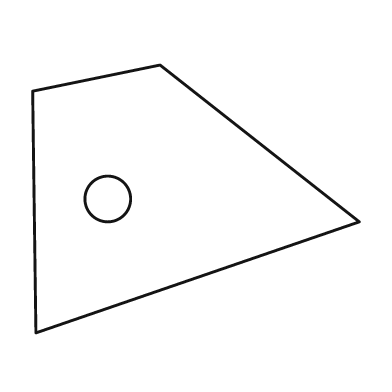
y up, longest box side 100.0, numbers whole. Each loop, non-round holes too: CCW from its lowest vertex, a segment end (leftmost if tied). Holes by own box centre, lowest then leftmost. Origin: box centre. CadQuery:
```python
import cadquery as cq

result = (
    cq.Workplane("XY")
    .moveTo(-49.0, -41.0)
    .lineTo(50.0, -7.0)
    .lineTo(-11.0, 41.0)
    .lineTo(-50.0, 33.0)
    .close()
    .moveTo(-27.0, 0.0)
    .circle(7.0)
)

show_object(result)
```